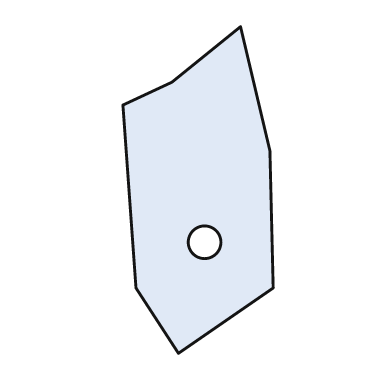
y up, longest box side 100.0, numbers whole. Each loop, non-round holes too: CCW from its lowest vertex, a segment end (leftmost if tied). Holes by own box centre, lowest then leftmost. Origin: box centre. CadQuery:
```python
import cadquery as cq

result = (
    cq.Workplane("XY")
    .moveTo(-6.0, -50.0)
    .lineTo(23.0, -30.0)
    .lineTo(22.0, 12.0)
    .lineTo(13.0, 50.0)
    .lineTo(-8.0, 33.0)
    .lineTo(-23.0, 26.0)
    .lineTo(-19.0, -30.0)
    .close()
    .moveTo(2.0, -16.0)
    .circle(5.0)
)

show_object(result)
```